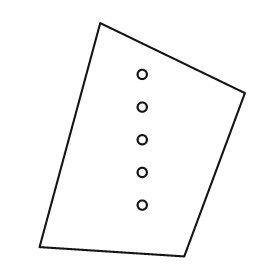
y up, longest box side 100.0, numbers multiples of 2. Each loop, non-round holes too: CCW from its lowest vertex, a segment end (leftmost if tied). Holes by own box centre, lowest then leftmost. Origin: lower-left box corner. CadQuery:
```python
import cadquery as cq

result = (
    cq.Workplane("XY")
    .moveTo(62.0, 0.0)
    .lineTo(88.0, 70.0)
    .lineTo(26.0, 100.0)
    .lineTo(0.0, 4.0)
    .close()
    .moveTo(44.0, 22.0)
    .circle(2.0)
    .moveTo(44.0, 36.0)
    .circle(2.0)
    .moveTo(44.0, 50.0)
    .circle(2.0)
    .moveTo(44.0, 64.0)
    .circle(2.0)
    .moveTo(44.0, 78.0)
    .circle(2.0)
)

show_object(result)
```